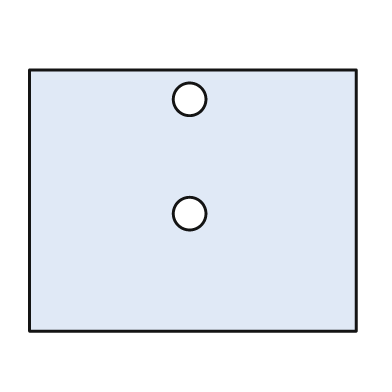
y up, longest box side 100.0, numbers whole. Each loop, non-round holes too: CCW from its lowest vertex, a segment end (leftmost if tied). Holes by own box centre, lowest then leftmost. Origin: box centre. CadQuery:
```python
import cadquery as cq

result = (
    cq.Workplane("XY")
    .moveTo(-50.0, -40.0)
    .lineTo(50.0, -40.0)
    .lineTo(50.0, 40.0)
    .lineTo(-50.0, 40.0)
    .close()
    .moveTo(-1.0, -4.0)
    .circle(5.0)
    .moveTo(-1.0, 31.0)
    .circle(5.0)
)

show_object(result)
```